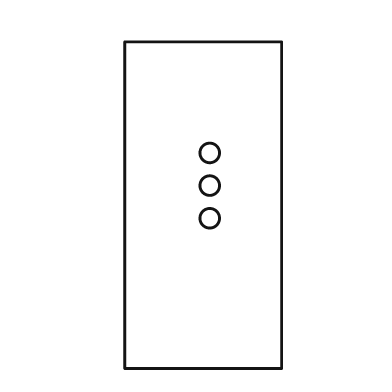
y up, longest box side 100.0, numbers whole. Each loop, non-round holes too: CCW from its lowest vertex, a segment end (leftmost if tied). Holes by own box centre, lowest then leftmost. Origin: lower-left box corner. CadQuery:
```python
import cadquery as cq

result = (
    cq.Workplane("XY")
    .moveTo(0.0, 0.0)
    .lineTo(48.0, 0.0)
    .lineTo(48.0, 100.0)
    .lineTo(0.0, 100.0)
    .close()
    .moveTo(26.0, 46.0)
    .circle(3.0)
    .moveTo(26.0, 56.0)
    .circle(3.0)
    .moveTo(26.0, 66.0)
    .circle(3.0)
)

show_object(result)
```